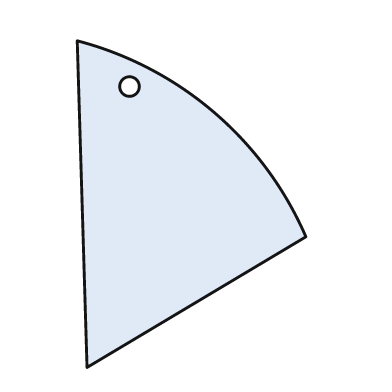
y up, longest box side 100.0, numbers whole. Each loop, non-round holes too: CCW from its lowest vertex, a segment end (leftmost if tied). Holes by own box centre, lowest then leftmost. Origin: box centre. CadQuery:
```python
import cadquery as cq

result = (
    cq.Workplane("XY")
    .moveTo(-32.0, -50.0)
    .lineTo(35.0, -10.0)
    .threePointArc((7.0, 28.0), (-35.0, 50.0))
    .close()
    .moveTo(-19.0, 36.0)
    .circle(3.0)
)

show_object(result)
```